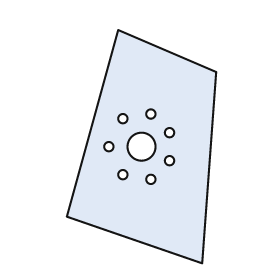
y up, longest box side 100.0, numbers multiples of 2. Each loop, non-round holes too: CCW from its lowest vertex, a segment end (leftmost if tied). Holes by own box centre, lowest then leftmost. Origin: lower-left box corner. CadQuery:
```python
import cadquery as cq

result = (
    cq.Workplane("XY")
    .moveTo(58.0, 0.0)
    .lineTo(64.0, 82.0)
    .lineTo(22.0, 100.0)
    .lineTo(0.0, 20.0)
    .close()
    .moveTo(36.0, 36.0)
    .circle(2.0)
    .moveTo(24.0, 38.0)
    .circle(2.0)
    .moveTo(44.0, 44.0)
    .circle(2.0)
    .moveTo(18.0, 50.0)
    .circle(2.0)
    .moveTo(32.0, 50.0)
    .circle(6.0)
    .moveTo(44.0, 56.0)
    .circle(2.0)
    .moveTo(24.0, 62.0)
    .circle(2.0)
    .moveTo(36.0, 64.0)
    .circle(2.0)
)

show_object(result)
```